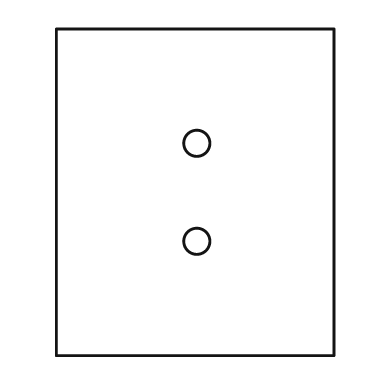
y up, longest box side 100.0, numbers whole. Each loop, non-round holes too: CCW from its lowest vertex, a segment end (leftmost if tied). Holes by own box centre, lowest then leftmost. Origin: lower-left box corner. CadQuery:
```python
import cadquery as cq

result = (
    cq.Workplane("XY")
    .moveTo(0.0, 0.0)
    .lineTo(85.0, 0.0)
    .lineTo(85.0, 100.0)
    .lineTo(0.0, 100.0)
    .close()
    .moveTo(43.0, 35.0)
    .circle(4.0)
    .moveTo(43.0, 65.0)
    .circle(4.0)
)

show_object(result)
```